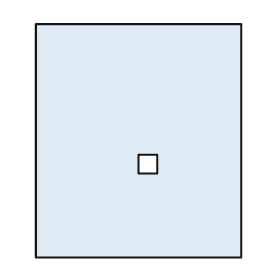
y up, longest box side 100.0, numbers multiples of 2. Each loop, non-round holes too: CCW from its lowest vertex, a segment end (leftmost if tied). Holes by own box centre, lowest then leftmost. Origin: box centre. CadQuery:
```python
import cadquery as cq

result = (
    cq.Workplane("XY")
    .moveTo(-44.0, -50.0)
    .lineTo(44.0, -50.0)
    .lineTo(44.0, 50.0)
    .lineTo(-44.0, 50.0)
    .close()
    .moveTo(0.0, -14.0)
    .lineTo(8.0, -14.0)
    .lineTo(8.0, -6.0)
    .lineTo(0.0, -6.0)
    .close()
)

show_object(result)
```